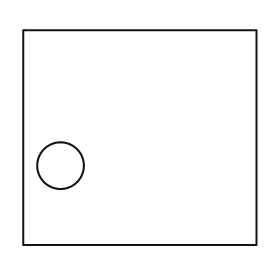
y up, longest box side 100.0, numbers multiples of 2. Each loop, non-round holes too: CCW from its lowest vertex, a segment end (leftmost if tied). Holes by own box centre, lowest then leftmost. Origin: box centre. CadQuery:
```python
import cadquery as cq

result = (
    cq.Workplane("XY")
    .moveTo(-50.0, -46.0)
    .lineTo(50.0, -46.0)
    .lineTo(50.0, 46.0)
    .lineTo(-50.0, 46.0)
    .close()
    .moveTo(-34.0, -12.0)
    .circle(10.0)
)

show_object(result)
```